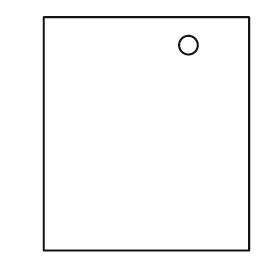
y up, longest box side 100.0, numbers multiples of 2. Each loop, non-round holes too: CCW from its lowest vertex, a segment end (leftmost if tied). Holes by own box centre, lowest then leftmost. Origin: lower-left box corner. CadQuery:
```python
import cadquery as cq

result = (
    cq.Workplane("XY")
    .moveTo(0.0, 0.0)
    .lineTo(88.0, 0.0)
    .lineTo(88.0, 100.0)
    .lineTo(0.0, 100.0)
    .close()
    .moveTo(62.0, 88.0)
    .circle(4.0)
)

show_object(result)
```